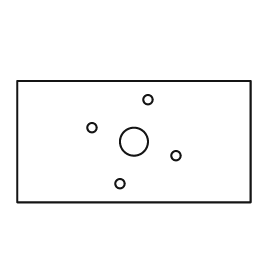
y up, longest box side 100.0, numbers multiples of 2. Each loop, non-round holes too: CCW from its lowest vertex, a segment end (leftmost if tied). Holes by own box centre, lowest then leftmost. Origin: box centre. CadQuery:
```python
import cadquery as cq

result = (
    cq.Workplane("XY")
    .moveTo(-50.0, -26.0)
    .lineTo(50.0, -26.0)
    .lineTo(50.0, 26.0)
    .lineTo(-50.0, 26.0)
    .close()
    .moveTo(-6.0, -18.0)
    .circle(2.0)
    .moveTo(18.0, -6.0)
    .circle(2.0)
    .moveTo(0.0, 0.0)
    .circle(6.0)
    .moveTo(-18.0, 6.0)
    .circle(2.0)
    .moveTo(6.0, 18.0)
    .circle(2.0)
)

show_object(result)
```